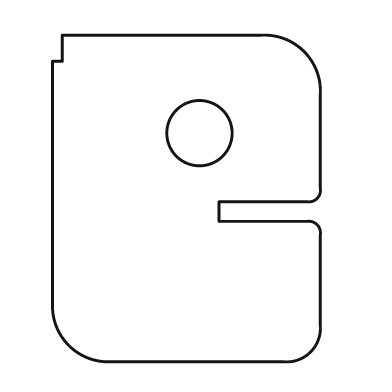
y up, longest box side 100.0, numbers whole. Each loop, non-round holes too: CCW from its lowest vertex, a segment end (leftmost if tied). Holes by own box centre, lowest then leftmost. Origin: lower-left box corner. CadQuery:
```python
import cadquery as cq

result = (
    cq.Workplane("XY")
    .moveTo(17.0, 0.0)
    .lineTo(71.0, 0.0)
    .threePointArc((79.0, 3.0), (82.0, 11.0))
    .lineTo(82.0, 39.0)
    .threePointArc((81.0, 42.0), (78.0, 43.0))
    .lineTo(51.0, 43.0)
    .lineTo(51.0, 49.0)
    .lineTo(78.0, 49.0)
    .threePointArc((81.0, 50.0), (82.0, 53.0))
    .lineTo(82.0, 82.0)
    .threePointArc((77.0, 95.0), (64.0, 100.0))
    .lineTo(3.0, 100.0)
    .lineTo(3.0, 92.0)
    .lineTo(0.0, 92.0)
    .lineTo(0.0, 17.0)
    .threePointArc((5.0, 5.0), (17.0, 0.0))
    .close()
    .moveTo(45.0, 70.0)
    .circle(10.0)
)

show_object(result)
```